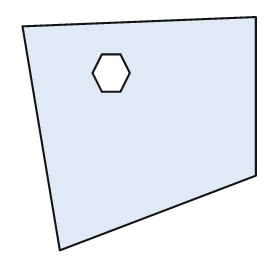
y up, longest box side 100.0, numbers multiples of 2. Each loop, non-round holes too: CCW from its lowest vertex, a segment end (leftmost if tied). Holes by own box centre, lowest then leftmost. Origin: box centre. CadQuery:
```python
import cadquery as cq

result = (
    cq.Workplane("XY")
    .moveTo(-34.0, -50.0)
    .lineTo(50.0, -18.0)
    .lineTo(50.0, 50.0)
    .lineTo(-50.0, 46.0)
    .close()
    .moveTo(-16.0, 18.0)
    .lineTo(-8.0, 18.0)
    .lineTo(-4.0, 26.0)
    .lineTo(-8.0, 34.0)
    .lineTo(-16.0, 34.0)
    .lineTo(-20.0, 26.0)
    .close()
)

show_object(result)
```